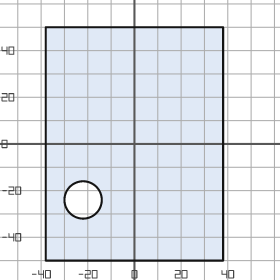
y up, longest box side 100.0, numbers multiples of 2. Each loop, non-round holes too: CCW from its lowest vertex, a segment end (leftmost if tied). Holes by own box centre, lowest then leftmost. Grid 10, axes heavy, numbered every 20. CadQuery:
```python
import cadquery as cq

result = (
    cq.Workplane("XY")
    .moveTo(-38.0, -50.0)
    .lineTo(38.0, -50.0)
    .lineTo(38.0, 50.0)
    .lineTo(-38.0, 50.0)
    .close()
    .moveTo(-22.0, -24.0)
    .circle(8.0)
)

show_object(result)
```